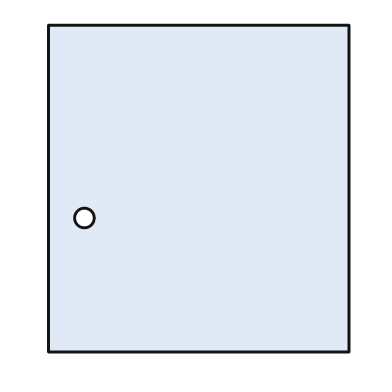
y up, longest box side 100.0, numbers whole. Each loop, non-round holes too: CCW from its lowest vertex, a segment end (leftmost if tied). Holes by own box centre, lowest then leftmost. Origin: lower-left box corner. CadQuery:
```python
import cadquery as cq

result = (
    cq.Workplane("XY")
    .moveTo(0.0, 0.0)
    .lineTo(92.0, 0.0)
    .lineTo(92.0, 100.0)
    .lineTo(0.0, 100.0)
    .close()
    .moveTo(11.0, 41.0)
    .circle(3.0)
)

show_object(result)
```